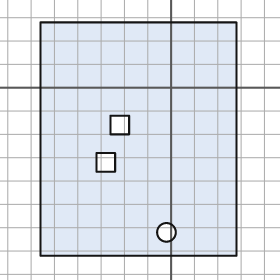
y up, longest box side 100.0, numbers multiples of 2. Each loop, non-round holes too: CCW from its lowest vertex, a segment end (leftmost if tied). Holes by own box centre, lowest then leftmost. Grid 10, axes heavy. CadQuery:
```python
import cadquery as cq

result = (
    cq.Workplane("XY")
    .moveTo(-56.0, -72.0)
    .lineTo(28.0, -72.0)
    .lineTo(28.0, 28.0)
    .lineTo(-56.0, 28.0)
    .close()
    .moveTo(-2.0, -62.0)
    .circle(4.0)
    .moveTo(-32.0, -36.0)
    .lineTo(-24.0, -36.0)
    .lineTo(-24.0, -28.0)
    .lineTo(-32.0, -28.0)
    .close()
    .moveTo(-26.0, -20.0)
    .lineTo(-18.0, -20.0)
    .lineTo(-18.0, -12.0)
    .lineTo(-26.0, -12.0)
    .close()
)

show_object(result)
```